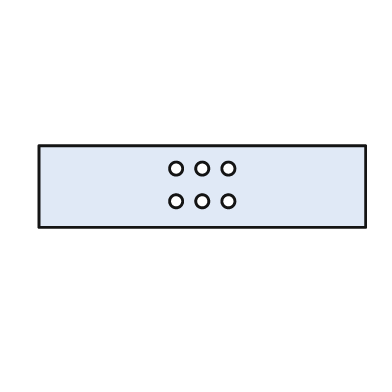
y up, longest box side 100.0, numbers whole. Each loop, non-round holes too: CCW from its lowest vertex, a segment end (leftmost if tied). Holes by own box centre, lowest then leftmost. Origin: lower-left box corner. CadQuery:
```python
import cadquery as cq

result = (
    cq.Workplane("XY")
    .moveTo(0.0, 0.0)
    .lineTo(100.0, 0.0)
    .lineTo(100.0, 25.0)
    .lineTo(0.0, 25.0)
    .close()
    .moveTo(42.0, 8.0)
    .circle(2.0)
    .moveTo(50.0, 8.0)
    .circle(2.0)
    .moveTo(58.0, 8.0)
    .circle(2.0)
    .moveTo(42.0, 18.0)
    .circle(2.0)
    .moveTo(50.0, 18.0)
    .circle(2.0)
    .moveTo(58.0, 18.0)
    .circle(2.0)
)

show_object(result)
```